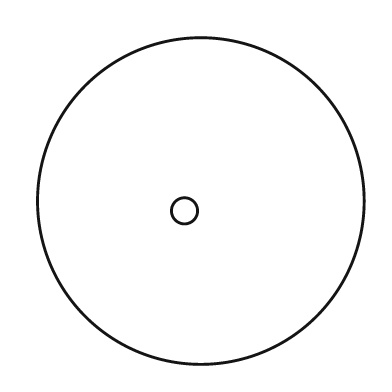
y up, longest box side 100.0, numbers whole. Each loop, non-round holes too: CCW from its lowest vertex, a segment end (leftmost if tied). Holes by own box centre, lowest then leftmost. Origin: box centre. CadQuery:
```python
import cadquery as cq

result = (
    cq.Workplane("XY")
    .moveTo(0.0, 0.0)
    .circle(50.0)
    .moveTo(-5.0, -3.0)
    .circle(4.0)
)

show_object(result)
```